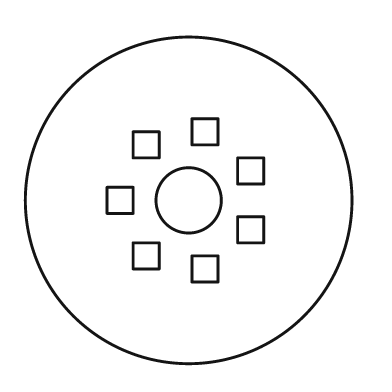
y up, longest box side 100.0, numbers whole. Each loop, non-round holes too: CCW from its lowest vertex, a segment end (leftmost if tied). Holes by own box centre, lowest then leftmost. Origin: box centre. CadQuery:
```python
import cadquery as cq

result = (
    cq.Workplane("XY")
    .moveTo(0.0, 0.0)
    .circle(50.0)
    .moveTo(1.0, -25.0)
    .lineTo(9.0, -25.0)
    .lineTo(9.0, -17.0)
    .lineTo(1.0, -17.0)
    .close()
    .moveTo(-17.0, -21.0)
    .lineTo(-9.0, -21.0)
    .lineTo(-9.0, -13.0)
    .lineTo(-17.0, -13.0)
    .close()
    .moveTo(15.0, -13.0)
    .lineTo(23.0, -13.0)
    .lineTo(23.0, -5.0)
    .lineTo(15.0, -5.0)
    .close()
    .moveTo(-25.0, -4.0)
    .lineTo(-17.0, -4.0)
    .lineTo(-17.0, 4.0)
    .lineTo(-25.0, 4.0)
    .close()
    .moveTo(0.0, 0.0)
    .circle(10.0)
    .moveTo(15.0, 5.0)
    .lineTo(23.0, 5.0)
    .lineTo(23.0, 13.0)
    .lineTo(15.0, 13.0)
    .close()
    .moveTo(-17.0, 13.0)
    .lineTo(-9.0, 13.0)
    .lineTo(-9.0, 21.0)
    .lineTo(-17.0, 21.0)
    .close()
    .moveTo(1.0, 17.0)
    .lineTo(9.0, 17.0)
    .lineTo(9.0, 25.0)
    .lineTo(1.0, 25.0)
    .close()
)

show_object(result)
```